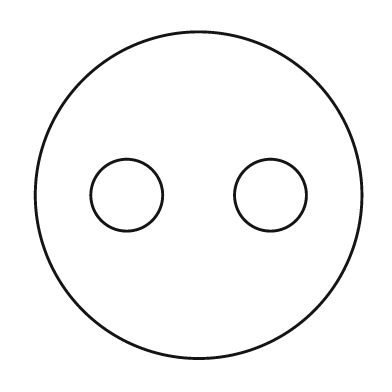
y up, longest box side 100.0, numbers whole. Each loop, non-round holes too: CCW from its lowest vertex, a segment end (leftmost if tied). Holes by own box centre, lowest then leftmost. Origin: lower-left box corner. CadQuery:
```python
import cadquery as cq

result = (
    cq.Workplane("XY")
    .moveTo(50.0, 50.0)
    .circle(50.0)
    .moveTo(28.0, 50.0)
    .circle(11.0)
    .moveTo(72.0, 50.0)
    .circle(11.0)
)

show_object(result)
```